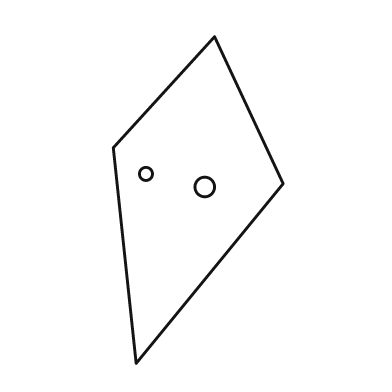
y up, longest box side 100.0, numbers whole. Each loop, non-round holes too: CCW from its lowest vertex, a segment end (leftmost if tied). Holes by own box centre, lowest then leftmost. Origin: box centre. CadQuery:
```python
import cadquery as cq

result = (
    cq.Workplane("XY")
    .moveTo(-19.0, -50.0)
    .lineTo(26.0, 5.0)
    .lineTo(5.0, 50.0)
    .lineTo(-26.0, 16.0)
    .close()
    .moveTo(2.0, 4.0)
    .circle(3.0)
    .moveTo(-16.0, 8.0)
    .circle(2.0)
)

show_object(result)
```